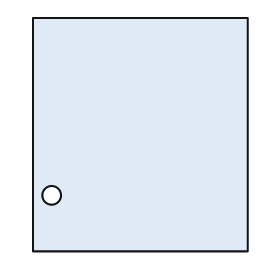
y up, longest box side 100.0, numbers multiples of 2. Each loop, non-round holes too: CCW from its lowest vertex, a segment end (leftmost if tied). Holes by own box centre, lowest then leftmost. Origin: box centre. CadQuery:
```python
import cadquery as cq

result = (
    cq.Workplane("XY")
    .moveTo(-46.0, -50.0)
    .lineTo(46.0, -50.0)
    .lineTo(46.0, 50.0)
    .lineTo(-46.0, 50.0)
    .close()
    .moveTo(-38.0, -26.0)
    .circle(4.0)
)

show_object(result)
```